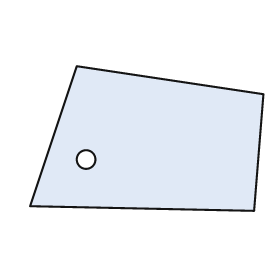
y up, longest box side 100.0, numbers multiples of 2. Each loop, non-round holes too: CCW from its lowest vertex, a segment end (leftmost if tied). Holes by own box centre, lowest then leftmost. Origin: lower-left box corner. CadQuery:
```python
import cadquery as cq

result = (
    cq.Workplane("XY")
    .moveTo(96.0, 0.0)
    .lineTo(100.0, 50.0)
    .lineTo(20.0, 62.0)
    .lineTo(0.0, 2.0)
    .close()
    .moveTo(24.0, 22.0)
    .circle(4.0)
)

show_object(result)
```